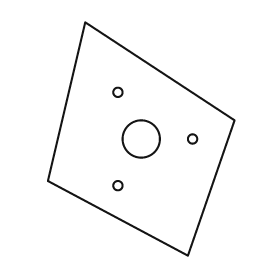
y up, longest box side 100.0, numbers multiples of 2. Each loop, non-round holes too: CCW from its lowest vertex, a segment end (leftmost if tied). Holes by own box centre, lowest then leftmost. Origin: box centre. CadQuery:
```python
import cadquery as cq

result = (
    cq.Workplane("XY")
    .moveTo(20.0, -50.0)
    .lineTo(40.0, 8.0)
    .lineTo(-24.0, 50.0)
    .lineTo(-40.0, -18.0)
    .close()
    .moveTo(-10.0, -20.0)
    .circle(2.0)
    .moveTo(0.0, 0.0)
    .circle(8.0)
    .moveTo(22.0, 0.0)
    .circle(2.0)
    .moveTo(-10.0, 20.0)
    .circle(2.0)
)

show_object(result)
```